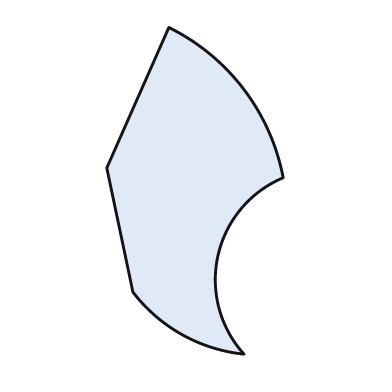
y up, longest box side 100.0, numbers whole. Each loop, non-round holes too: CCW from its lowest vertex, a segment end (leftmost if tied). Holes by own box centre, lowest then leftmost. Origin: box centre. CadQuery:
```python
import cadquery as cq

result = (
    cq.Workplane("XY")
    .moveTo(15.0, -50.0)
    .threePointArc((7.0, -20.0), (27.0, 4.0))
    .threePointArc((15.0, 31.0), (-8.0, 50.0))
    .lineTo(-27.0, 7.0)
    .lineTo(-19.0, -31.0)
    .threePointArc((-4.0, -44.0), (15.0, -50.0))
    .close()
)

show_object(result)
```